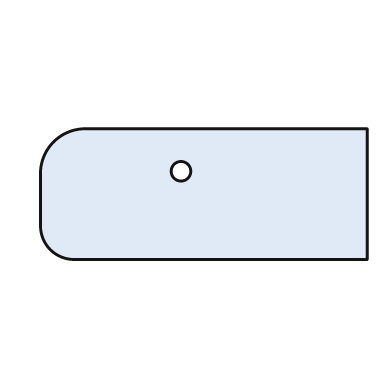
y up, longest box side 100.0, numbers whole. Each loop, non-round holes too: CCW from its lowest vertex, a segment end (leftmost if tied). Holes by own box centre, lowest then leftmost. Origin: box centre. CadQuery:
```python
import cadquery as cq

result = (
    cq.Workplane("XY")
    .moveTo(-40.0, -20.0)
    .lineTo(50.0, -20.0)
    .lineTo(50.0, 20.0)
    .lineTo(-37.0, 20.0)
    .threePointArc((-46.0, 16.0), (-50.0, 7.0))
    .lineTo(-50.0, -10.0)
    .threePointArc((-47.0, -17.0), (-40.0, -20.0))
    .close()
    .moveTo(-7.0, 7.0)
    .circle(3.0)
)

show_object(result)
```